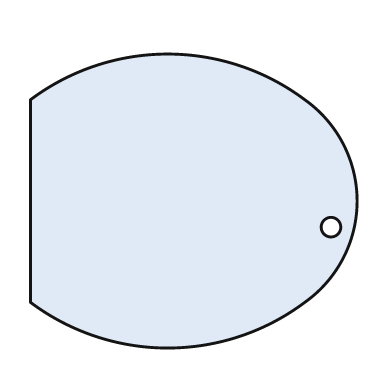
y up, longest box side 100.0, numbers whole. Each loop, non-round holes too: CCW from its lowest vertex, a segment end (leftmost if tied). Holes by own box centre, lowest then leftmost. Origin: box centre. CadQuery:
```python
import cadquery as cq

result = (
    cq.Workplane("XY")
    .moveTo(-50.0, -31.0)
    .threePointArc((-8.0, -45.0), (34.0, -31.0))
    .threePointArc((50.0, 0.0), (34.0, 31.0))
    .threePointArc((-8.0, 45.0), (-50.0, 31.0))
    .close()
    .moveTo(42.0, -8.0)
    .circle(3.0)
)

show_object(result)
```